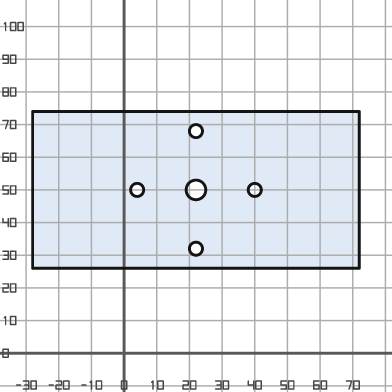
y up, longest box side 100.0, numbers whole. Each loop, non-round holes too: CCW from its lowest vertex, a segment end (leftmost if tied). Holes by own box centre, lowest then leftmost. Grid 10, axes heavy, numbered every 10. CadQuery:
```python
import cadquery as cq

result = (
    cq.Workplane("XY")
    .moveTo(-28.0, 26.0)
    .lineTo(72.0, 26.0)
    .lineTo(72.0, 74.0)
    .lineTo(-28.0, 74.0)
    .close()
    .moveTo(22.0, 32.0)
    .circle(2.0)
    .moveTo(4.0, 50.0)
    .circle(2.0)
    .moveTo(22.0, 50.0)
    .circle(3.0)
    .moveTo(40.0, 50.0)
    .circle(2.0)
    .moveTo(22.0, 68.0)
    .circle(2.0)
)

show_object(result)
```